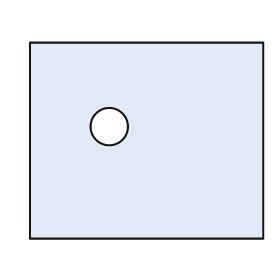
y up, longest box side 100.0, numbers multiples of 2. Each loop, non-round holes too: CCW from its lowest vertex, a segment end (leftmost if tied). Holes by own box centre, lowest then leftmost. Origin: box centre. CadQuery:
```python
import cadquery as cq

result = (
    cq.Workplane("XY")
    .moveTo(-50.0, -42.0)
    .lineTo(50.0, -42.0)
    .lineTo(50.0, 42.0)
    .lineTo(-50.0, 42.0)
    .close()
    .moveTo(-16.0, 6.0)
    .circle(8.0)
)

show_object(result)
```